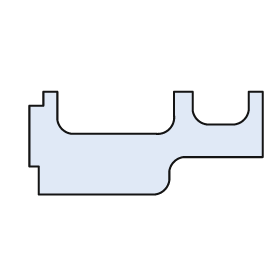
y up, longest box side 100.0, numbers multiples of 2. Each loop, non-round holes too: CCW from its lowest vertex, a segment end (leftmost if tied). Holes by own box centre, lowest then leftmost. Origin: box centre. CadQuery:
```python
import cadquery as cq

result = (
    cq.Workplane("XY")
    .moveTo(-46.0, -22.0)
    .lineTo(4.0, -22.0)
    .threePointArc((8.0, -20.0), (10.0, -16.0))
    .lineTo(10.0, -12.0)
    .threePointArc((12.0, -8.0), (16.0, -6.0))
    .lineTo(50.0, -6.0)
    .lineTo(50.0, 22.0)
    .lineTo(44.0, 22.0)
    .lineTo(44.0, 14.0)
    .threePointArc((42.0, 10.0), (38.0, 8.0))
    .lineTo(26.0, 8.0)
    .threePointArc((22.0, 10.0), (20.0, 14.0))
    .lineTo(20.0, 22.0)
    .lineTo(12.0, 22.0)
    .lineTo(12.0, 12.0)
    .threePointArc((10.0, 6.0), (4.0, 4.0))
    .lineTo(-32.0, 4.0)
    .threePointArc((-36.0, 6.0), (-38.0, 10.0))
    .lineTo(-38.0, 22.0)
    .lineTo(-44.0, 22.0)
    .lineTo(-44.0, 16.0)
    .lineTo(-50.0, 16.0)
    .lineTo(-50.0, -10.0)
    .lineTo(-46.0, -10.0)
    .close()
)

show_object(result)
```